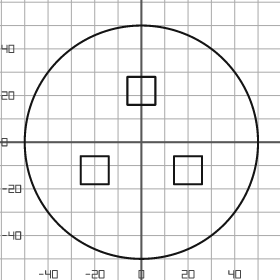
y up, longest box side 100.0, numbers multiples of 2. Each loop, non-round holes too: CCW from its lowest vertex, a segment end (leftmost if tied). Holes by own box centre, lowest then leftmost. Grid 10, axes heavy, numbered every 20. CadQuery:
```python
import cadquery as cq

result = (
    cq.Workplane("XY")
    .moveTo(0.0, 0.0)
    .circle(50.0)
    .moveTo(-26.0, -18.0)
    .lineTo(-14.0, -18.0)
    .lineTo(-14.0, -6.0)
    .lineTo(-26.0, -6.0)
    .close()
    .moveTo(14.0, -18.0)
    .lineTo(26.0, -18.0)
    .lineTo(26.0, -6.0)
    .lineTo(14.0, -6.0)
    .close()
    .moveTo(-6.0, 16.0)
    .lineTo(6.0, 16.0)
    .lineTo(6.0, 28.0)
    .lineTo(-6.0, 28.0)
    .close()
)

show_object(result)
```